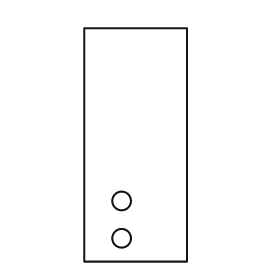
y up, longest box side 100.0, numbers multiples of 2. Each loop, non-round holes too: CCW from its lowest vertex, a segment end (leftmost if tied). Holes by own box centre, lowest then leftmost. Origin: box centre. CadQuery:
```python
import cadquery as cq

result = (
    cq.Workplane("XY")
    .moveTo(-22.0, -50.0)
    .lineTo(22.0, -50.0)
    .lineTo(22.0, 50.0)
    .lineTo(-22.0, 50.0)
    .close()
    .moveTo(-6.0, -40.0)
    .circle(4.0)
    .moveTo(-6.0, -24.0)
    .circle(4.0)
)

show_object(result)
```